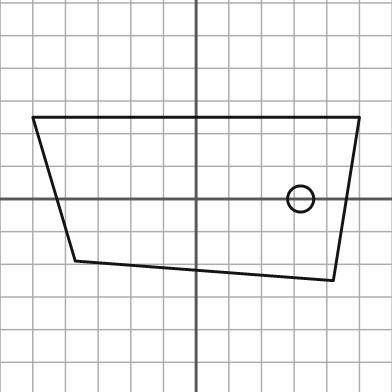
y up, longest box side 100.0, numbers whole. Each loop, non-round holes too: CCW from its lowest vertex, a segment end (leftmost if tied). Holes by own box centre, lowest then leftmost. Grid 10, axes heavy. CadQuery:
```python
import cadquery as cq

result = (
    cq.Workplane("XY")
    .moveTo(42.0, -25.0)
    .lineTo(50.0, 25.0)
    .lineTo(-50.0, 25.0)
    .lineTo(-37.0, -19.0)
    .close()
    .moveTo(32.0, 0.0)
    .circle(4.0)
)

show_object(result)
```